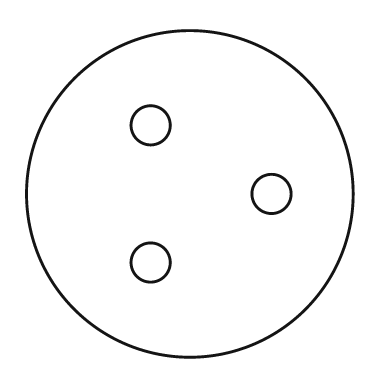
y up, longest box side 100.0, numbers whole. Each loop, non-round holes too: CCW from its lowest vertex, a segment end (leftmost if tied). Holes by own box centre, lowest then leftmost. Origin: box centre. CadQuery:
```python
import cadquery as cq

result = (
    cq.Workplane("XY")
    .moveTo(0.0, 0.0)
    .circle(50.0)
    .moveTo(-12.0, -21.0)
    .circle(6.0)
    .moveTo(25.0, 0.0)
    .circle(6.0)
    .moveTo(-12.0, 21.0)
    .circle(6.0)
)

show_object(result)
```